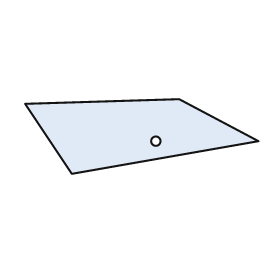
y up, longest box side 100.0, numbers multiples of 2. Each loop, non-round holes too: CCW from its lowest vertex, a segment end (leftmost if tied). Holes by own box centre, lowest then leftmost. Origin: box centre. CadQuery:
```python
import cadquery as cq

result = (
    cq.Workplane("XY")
    .moveTo(-30.0, -16.0)
    .lineTo(50.0, -2.0)
    .lineTo(16.0, 16.0)
    .lineTo(-50.0, 14.0)
    .close()
    .moveTo(6.0, -2.0)
    .circle(2.0)
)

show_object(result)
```